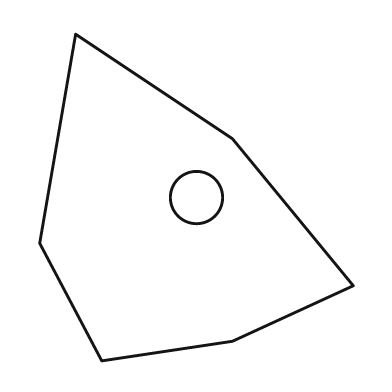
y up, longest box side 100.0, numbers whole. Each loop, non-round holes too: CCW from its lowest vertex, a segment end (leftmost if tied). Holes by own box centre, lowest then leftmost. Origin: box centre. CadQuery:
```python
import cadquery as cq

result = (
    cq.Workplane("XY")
    .moveTo(-29.0, -50.0)
    .lineTo(11.0, -44.0)
    .lineTo(48.0, -27.0)
    .lineTo(11.0, 18.0)
    .lineTo(-37.0, 50.0)
    .lineTo(-48.0, -14.0)
    .close()
    .moveTo(0.0, 0.0)
    .circle(8.0)
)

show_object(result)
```